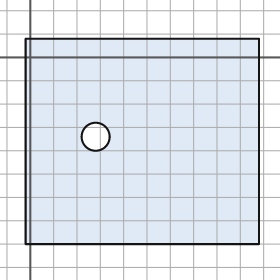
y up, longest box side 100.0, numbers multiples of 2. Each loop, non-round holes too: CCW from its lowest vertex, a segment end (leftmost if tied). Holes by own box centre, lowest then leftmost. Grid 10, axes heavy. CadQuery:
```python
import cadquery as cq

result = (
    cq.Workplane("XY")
    .moveTo(-2.0, -80.0)
    .lineTo(98.0, -80.0)
    .lineTo(98.0, 8.0)
    .lineTo(-2.0, 8.0)
    .close()
    .moveTo(28.0, -34.0)
    .circle(6.0)
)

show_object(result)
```